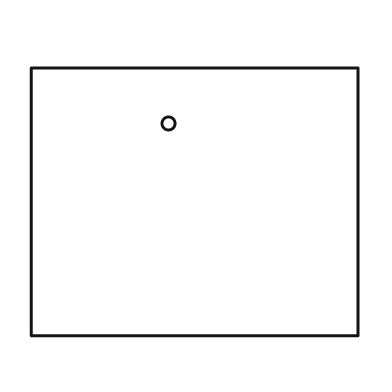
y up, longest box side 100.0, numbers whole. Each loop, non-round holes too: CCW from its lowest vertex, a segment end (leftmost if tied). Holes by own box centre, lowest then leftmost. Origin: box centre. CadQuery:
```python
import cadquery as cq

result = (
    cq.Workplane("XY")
    .moveTo(-50.0, -41.0)
    .lineTo(50.0, -41.0)
    .lineTo(50.0, 41.0)
    .lineTo(-50.0, 41.0)
    .close()
    .moveTo(-8.0, 24.0)
    .circle(2.0)
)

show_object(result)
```